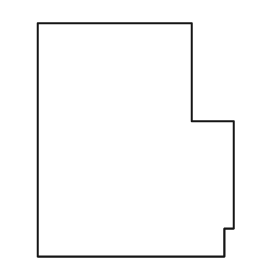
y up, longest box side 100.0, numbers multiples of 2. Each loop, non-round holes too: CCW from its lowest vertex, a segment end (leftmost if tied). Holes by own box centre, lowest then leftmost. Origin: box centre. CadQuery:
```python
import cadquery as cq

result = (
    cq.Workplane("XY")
    .moveTo(-42.0, -50.0)
    .lineTo(38.0, -50.0)
    .lineTo(38.0, -38.0)
    .lineTo(42.0, -38.0)
    .lineTo(42.0, 8.0)
    .lineTo(24.0, 8.0)
    .lineTo(24.0, 50.0)
    .lineTo(-42.0, 50.0)
    .close()
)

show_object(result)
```